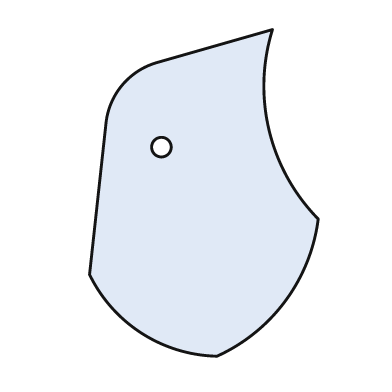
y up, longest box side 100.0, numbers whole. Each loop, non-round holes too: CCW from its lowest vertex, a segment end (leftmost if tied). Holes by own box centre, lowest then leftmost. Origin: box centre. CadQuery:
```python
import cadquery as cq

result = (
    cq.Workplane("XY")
    .moveTo(4.0, -50.0)
    .threePointArc((25.0, -33.0), (35.0, -8.0))
    .threePointArc((20.0, 19.0), (21.0, 50.0))
    .lineTo(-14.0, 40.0)
    .threePointArc((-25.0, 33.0), (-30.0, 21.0))
    .lineTo(-35.0, -25.0)
    .threePointArc((-19.0, -43.0), (4.0, -50.0))
    .close()
    .moveTo(-13.0, 14.0)
    .circle(3.0)
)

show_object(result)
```